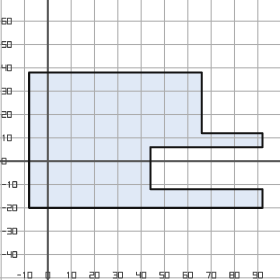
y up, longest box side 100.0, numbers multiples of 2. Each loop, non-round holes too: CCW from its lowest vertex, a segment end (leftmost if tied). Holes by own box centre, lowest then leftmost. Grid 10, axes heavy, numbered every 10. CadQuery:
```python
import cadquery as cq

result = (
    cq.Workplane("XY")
    .moveTo(-8.0, -20.0)
    .lineTo(92.0, -20.0)
    .lineTo(92.0, -12.0)
    .lineTo(44.0, -12.0)
    .lineTo(44.0, 6.0)
    .lineTo(92.0, 6.0)
    .lineTo(92.0, 12.0)
    .lineTo(66.0, 12.0)
    .lineTo(66.0, 38.0)
    .lineTo(-8.0, 38.0)
    .close()
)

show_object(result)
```